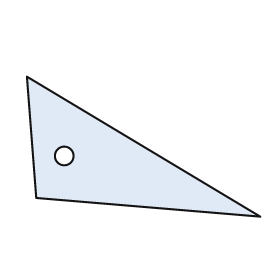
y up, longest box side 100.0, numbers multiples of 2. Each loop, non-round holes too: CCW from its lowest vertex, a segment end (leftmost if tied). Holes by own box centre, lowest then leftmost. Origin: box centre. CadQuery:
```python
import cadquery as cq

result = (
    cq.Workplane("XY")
    .moveTo(50.0, -30.0)
    .lineTo(-50.0, 30.0)
    .lineTo(-46.0, -22.0)
    .close()
    .moveTo(-34.0, -4.0)
    .circle(4.0)
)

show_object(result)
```